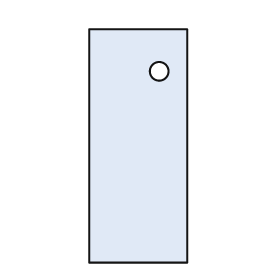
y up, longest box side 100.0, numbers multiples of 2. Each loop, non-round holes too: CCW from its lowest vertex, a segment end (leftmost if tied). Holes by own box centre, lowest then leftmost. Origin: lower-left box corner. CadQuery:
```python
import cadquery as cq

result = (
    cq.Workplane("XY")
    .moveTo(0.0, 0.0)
    .lineTo(42.0, 0.0)
    .lineTo(42.0, 100.0)
    .lineTo(0.0, 100.0)
    .close()
    .moveTo(30.0, 82.0)
    .circle(4.0)
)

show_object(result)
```